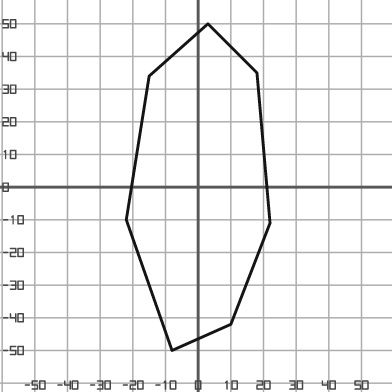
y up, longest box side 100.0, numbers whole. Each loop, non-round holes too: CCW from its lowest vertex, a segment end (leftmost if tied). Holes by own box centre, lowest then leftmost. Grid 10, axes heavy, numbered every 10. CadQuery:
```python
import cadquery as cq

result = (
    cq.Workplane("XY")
    .moveTo(-8.0, -50.0)
    .lineTo(10.0, -42.0)
    .lineTo(22.0, -11.0)
    .lineTo(18.0, 35.0)
    .lineTo(3.0, 50.0)
    .lineTo(-15.0, 34.0)
    .lineTo(-22.0, -10.0)
    .close()
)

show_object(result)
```